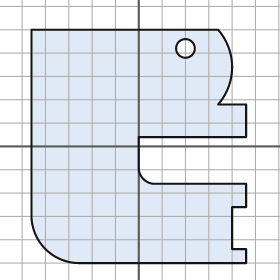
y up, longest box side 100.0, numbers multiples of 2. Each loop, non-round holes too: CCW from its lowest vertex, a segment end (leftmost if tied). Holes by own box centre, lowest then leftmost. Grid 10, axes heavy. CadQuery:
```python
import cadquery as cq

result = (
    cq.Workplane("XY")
    .moveTo(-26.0, -50.0)
    .lineTo(46.0, -50.0)
    .lineTo(46.0, -44.0)
    .lineTo(40.0, -44.0)
    .lineTo(40.0, -26.0)
    .lineTo(46.0, -26.0)
    .lineTo(46.0, -16.0)
    .lineTo(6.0, -16.0)
    .threePointArc((2.0, -14.0), (0.0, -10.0))
    .lineTo(0.0, 4.0)
    .lineTo(46.0, 4.0)
    .lineTo(46.0, 18.0)
    .lineTo(34.0, 18.0)
    .threePointArc((40.0, 34.0), (34.0, 50.0))
    .lineTo(-46.0, 50.0)
    .lineTo(-46.0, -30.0)
    .threePointArc((-40.0, -44.0), (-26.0, -50.0))
    .close()
    .moveTo(20.0, 42.0)
    .circle(4.0)
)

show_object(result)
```